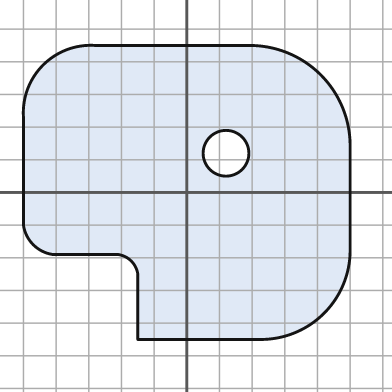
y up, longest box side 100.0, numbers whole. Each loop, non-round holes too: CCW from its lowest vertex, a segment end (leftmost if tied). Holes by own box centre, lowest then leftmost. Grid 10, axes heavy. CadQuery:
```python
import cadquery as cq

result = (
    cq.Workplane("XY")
    .moveTo(-15.0, -45.0)
    .lineTo(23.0, -45.0)
    .threePointArc((42.0, -37.0), (50.0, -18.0))
    .lineTo(50.0, 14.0)
    .threePointArc((41.0, 36.0), (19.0, 45.0))
    .lineTo(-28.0, 45.0)
    .threePointArc((-44.0, 39.0), (-50.0, 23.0))
    .lineTo(-50.0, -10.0)
    .threePointArc((-47.0, -16.0), (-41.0, -19.0))
    .lineTo(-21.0, -19.0)
    .threePointArc((-17.0, -21.0), (-15.0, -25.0))
    .close()
    .moveTo(12.0, 12.0)
    .circle(7.0)
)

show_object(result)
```